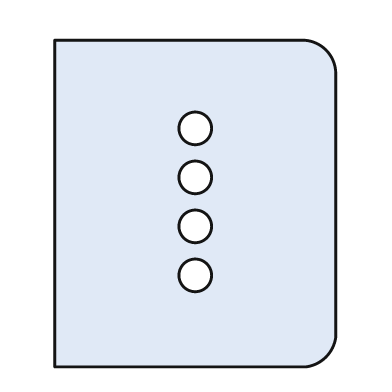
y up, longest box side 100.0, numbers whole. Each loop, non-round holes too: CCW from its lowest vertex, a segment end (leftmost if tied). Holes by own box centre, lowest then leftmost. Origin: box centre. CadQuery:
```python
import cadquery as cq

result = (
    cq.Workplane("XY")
    .moveTo(-43.0, -50.0)
    .lineTo(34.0, -50.0)
    .threePointArc((40.0, -47.0), (43.0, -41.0))
    .lineTo(43.0, 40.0)
    .threePointArc((40.0, 47.0), (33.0, 50.0))
    .lineTo(-43.0, 50.0)
    .close()
    .moveTo(0.0, -22.0)
    .circle(5.0)
    .moveTo(0.0, -7.0)
    .circle(5.0)
    .moveTo(0.0, 8.0)
    .circle(5.0)
    .moveTo(0.0, 23.0)
    .circle(5.0)
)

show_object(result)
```